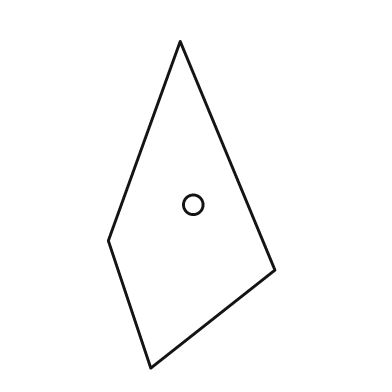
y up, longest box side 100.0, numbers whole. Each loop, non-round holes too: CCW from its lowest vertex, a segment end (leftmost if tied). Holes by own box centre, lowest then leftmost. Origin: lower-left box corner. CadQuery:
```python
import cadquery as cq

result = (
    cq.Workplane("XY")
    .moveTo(13.0, 0.0)
    .lineTo(51.0, 30.0)
    .lineTo(22.0, 100.0)
    .lineTo(0.0, 39.0)
    .close()
    .moveTo(26.0, 50.0)
    .circle(3.0)
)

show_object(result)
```